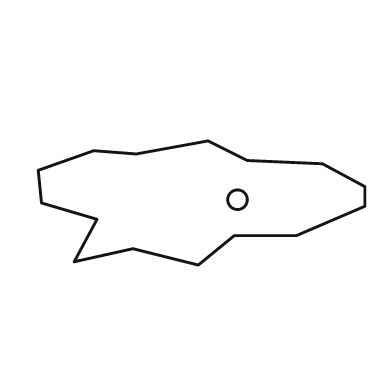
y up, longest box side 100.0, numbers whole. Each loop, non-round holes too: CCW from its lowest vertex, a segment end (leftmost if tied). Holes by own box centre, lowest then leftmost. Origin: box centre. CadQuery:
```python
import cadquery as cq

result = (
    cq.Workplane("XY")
    .moveTo(-1.0, -19.0)
    .lineTo(10.0, -10.0)
    .lineTo(29.0, -10.0)
    .lineTo(50.0, -1.0)
    .lineTo(50.0, 5.0)
    .lineTo(37.0, 12.0)
    .lineTo(14.0, 13.0)
    .lineTo(2.0, 19.0)
    .lineTo(-20.0, 15.0)
    .lineTo(-33.0, 16.0)
    .lineTo(-50.0, 10.0)
    .lineTo(-49.0, 0.0)
    .lineTo(-32.0, -5.0)
    .lineTo(-39.0, -18.0)
    .lineTo(-21.0, -14.0)
    .close()
    .moveTo(11.0, 1.0)
    .circle(3.0)
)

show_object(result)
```